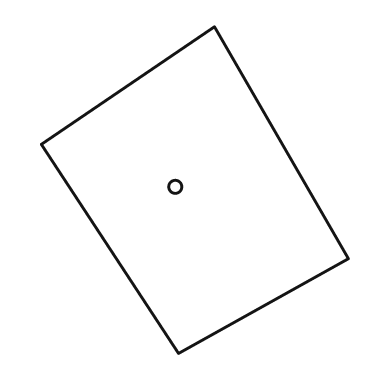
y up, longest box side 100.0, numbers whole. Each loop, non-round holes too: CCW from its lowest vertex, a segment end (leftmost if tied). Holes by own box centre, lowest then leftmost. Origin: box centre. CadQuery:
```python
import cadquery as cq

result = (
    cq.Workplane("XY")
    .moveTo(-5.0, -50.0)
    .lineTo(47.0, -21.0)
    .lineTo(6.0, 50.0)
    .lineTo(-47.0, 14.0)
    .close()
    .moveTo(-6.0, 1.0)
    .circle(2.0)
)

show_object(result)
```